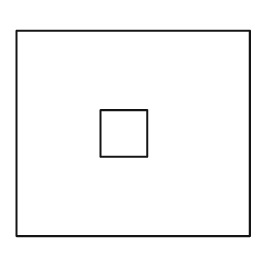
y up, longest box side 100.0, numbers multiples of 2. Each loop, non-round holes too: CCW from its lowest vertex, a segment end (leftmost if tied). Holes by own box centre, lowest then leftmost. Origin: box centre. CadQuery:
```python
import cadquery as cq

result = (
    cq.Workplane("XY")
    .moveTo(-50.0, -44.0)
    .lineTo(50.0, -44.0)
    .lineTo(50.0, 44.0)
    .lineTo(-50.0, 44.0)
    .close()
    .moveTo(-14.0, -10.0)
    .lineTo(6.0, -10.0)
    .lineTo(6.0, 10.0)
    .lineTo(-14.0, 10.0)
    .close()
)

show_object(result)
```